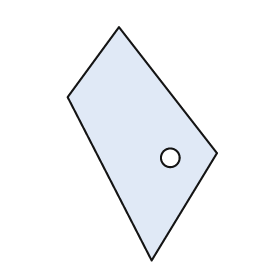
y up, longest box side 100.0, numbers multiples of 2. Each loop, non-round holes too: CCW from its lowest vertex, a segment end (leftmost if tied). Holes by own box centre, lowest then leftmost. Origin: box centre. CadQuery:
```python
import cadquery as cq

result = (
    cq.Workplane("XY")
    .moveTo(4.0, -50.0)
    .lineTo(32.0, -4.0)
    .lineTo(-10.0, 50.0)
    .lineTo(-32.0, 20.0)
    .close()
    .moveTo(12.0, -6.0)
    .circle(4.0)
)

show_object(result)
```